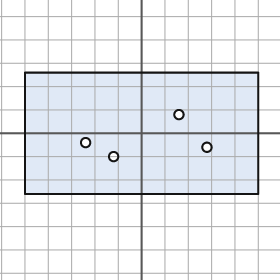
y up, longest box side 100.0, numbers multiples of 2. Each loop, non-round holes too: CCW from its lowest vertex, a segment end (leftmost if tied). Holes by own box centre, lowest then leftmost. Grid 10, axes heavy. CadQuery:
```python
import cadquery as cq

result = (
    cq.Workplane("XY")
    .moveTo(-50.0, -26.0)
    .lineTo(50.0, -26.0)
    .lineTo(50.0, 26.0)
    .lineTo(-50.0, 26.0)
    .close()
    .moveTo(-12.0, -10.0)
    .circle(2.0)
    .moveTo(28.0, -6.0)
    .circle(2.0)
    .moveTo(-24.0, -4.0)
    .circle(2.0)
    .moveTo(16.0, 8.0)
    .circle(2.0)
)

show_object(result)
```